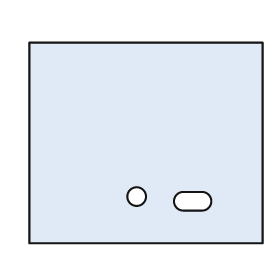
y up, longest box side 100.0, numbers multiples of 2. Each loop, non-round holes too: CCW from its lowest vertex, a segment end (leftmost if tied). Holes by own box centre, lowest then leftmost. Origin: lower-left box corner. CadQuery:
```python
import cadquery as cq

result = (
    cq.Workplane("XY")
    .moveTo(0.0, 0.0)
    .lineTo(100.0, 0.0)
    .lineTo(100.0, 86.0)
    .lineTo(0.0, 86.0)
    .close()
    .moveTo(66.0, 14.0)
    .lineTo(74.0, 14.0)
    .threePointArc((78.0, 18.0), (74.0, 22.0))
    .lineTo(66.0, 22.0)
    .threePointArc((62.0, 18.0), (66.0, 14.0))
    .close()
    .moveTo(46.0, 20.0)
    .circle(4.0)
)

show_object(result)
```